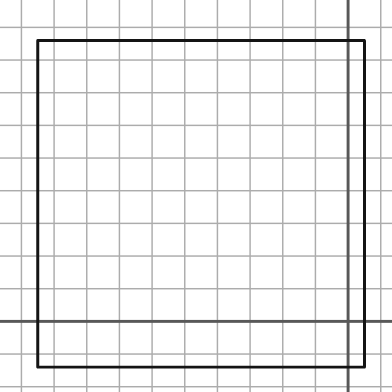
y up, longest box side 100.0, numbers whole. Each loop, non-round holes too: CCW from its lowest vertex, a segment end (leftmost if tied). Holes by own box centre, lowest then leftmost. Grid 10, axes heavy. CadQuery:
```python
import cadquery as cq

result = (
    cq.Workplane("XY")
    .moveTo(-95.0, -14.0)
    .lineTo(5.0, -14.0)
    .lineTo(5.0, 86.0)
    .lineTo(-95.0, 86.0)
    .close()
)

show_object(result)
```